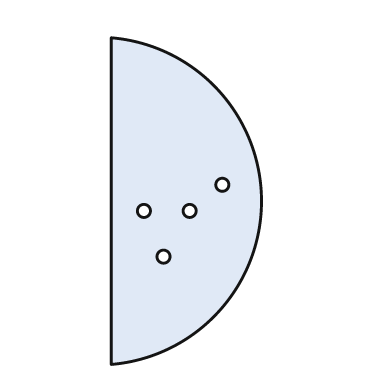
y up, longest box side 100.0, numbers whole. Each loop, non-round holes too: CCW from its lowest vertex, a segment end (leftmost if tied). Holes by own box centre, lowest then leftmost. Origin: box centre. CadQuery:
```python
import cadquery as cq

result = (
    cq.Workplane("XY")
    .moveTo(-23.0, -50.0)
    .threePointArc((23.0, 0.0), (-23.0, 50.0))
    .close()
    .moveTo(-7.0, -17.0)
    .circle(2.0)
    .moveTo(-13.0, -3.0)
    .circle(2.0)
    .moveTo(1.0, -3.0)
    .circle(2.0)
    .moveTo(11.0, 5.0)
    .circle(2.0)
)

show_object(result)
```